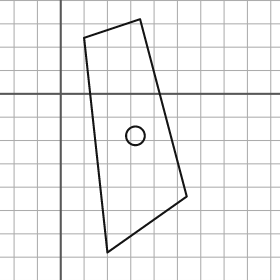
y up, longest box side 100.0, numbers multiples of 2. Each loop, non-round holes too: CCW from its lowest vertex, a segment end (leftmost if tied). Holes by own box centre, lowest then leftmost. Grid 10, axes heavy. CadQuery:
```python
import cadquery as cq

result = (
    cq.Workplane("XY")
    .moveTo(20.0, -68.0)
    .lineTo(54.0, -44.0)
    .lineTo(34.0, 32.0)
    .lineTo(10.0, 24.0)
    .close()
    .moveTo(32.0, -18.0)
    .circle(4.0)
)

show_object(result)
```